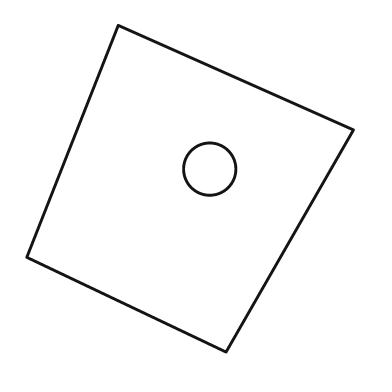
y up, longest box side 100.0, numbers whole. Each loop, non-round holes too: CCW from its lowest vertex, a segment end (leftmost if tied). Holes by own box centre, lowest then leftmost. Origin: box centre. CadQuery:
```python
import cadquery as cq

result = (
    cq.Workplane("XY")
    .moveTo(11.0, -50.0)
    .lineTo(50.0, 18.0)
    .lineTo(-22.0, 50.0)
    .lineTo(-50.0, -21.0)
    .close()
    .moveTo(6.0, 6.0)
    .circle(8.0)
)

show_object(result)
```